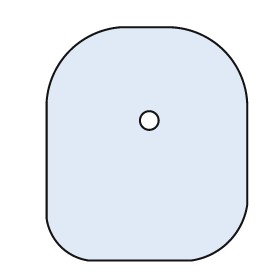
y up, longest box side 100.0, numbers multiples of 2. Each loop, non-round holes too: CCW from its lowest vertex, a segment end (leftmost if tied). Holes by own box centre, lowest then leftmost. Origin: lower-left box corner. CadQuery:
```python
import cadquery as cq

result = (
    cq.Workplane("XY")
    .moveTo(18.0, 0.0)
    .lineTo(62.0, 0.0)
    .threePointArc((78.0, 8.0), (86.0, 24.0))
    .lineTo(86.0, 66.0)
    .threePointArc((76.0, 90.0), (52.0, 100.0))
    .lineTo(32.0, 100.0)
    .threePointArc((10.0, 90.0), (0.0, 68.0))
    .lineTo(0.0, 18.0)
    .threePointArc((6.0, 6.0), (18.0, 0.0))
    .close()
    .moveTo(44.0, 60.0)
    .circle(4.0)
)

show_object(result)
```